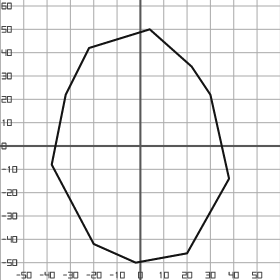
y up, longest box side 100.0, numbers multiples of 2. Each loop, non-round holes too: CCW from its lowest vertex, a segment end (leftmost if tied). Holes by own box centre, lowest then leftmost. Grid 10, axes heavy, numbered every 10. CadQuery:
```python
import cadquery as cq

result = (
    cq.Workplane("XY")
    .moveTo(-2.0, -50.0)
    .lineTo(20.0, -46.0)
    .lineTo(38.0, -14.0)
    .lineTo(30.0, 22.0)
    .lineTo(22.0, 34.0)
    .lineTo(4.0, 50.0)
    .lineTo(-22.0, 42.0)
    .lineTo(-32.0, 22.0)
    .lineTo(-38.0, -8.0)
    .lineTo(-20.0, -42.0)
    .close()
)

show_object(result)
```